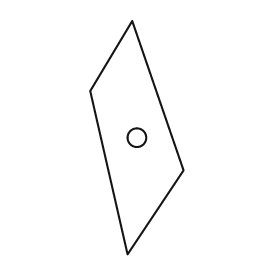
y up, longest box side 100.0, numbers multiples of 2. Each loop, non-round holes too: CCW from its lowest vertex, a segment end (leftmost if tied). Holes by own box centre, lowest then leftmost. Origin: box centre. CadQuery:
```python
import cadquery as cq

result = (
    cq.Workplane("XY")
    .moveTo(-4.0, -50.0)
    .lineTo(20.0, -14.0)
    .lineTo(-2.0, 50.0)
    .lineTo(-20.0, 20.0)
    .close()
    .moveTo(0.0, 0.0)
    .circle(4.0)
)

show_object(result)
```